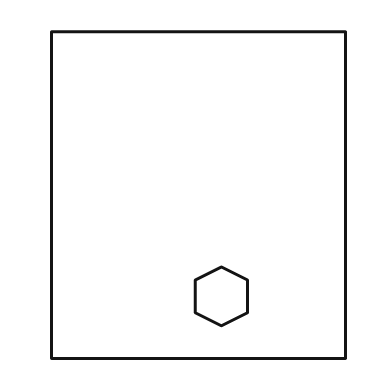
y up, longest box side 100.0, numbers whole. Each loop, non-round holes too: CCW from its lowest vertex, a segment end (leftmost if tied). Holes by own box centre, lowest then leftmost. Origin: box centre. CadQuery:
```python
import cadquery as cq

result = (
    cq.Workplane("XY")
    .moveTo(-45.0, -50.0)
    .lineTo(45.0, -50.0)
    .lineTo(45.0, 50.0)
    .lineTo(-45.0, 50.0)
    .close()
    .moveTo(7.0, -40.0)
    .lineTo(15.0, -36.0)
    .lineTo(15.0, -26.0)
    .lineTo(7.0, -22.0)
    .lineTo(-1.0, -26.0)
    .lineTo(-1.0, -36.0)
    .close()
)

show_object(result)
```